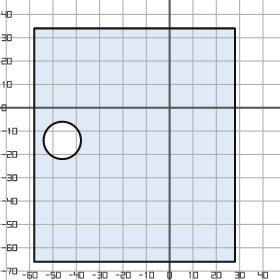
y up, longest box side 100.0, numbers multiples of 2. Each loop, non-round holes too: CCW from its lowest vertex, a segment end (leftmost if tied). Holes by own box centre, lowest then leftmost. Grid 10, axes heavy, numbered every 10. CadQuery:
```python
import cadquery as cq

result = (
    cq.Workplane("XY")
    .moveTo(-58.0, -66.0)
    .lineTo(28.0, -66.0)
    .lineTo(28.0, 34.0)
    .lineTo(-58.0, 34.0)
    .close()
    .moveTo(-46.0, -14.0)
    .circle(8.0)
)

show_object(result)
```